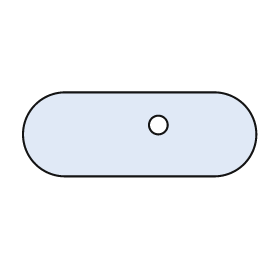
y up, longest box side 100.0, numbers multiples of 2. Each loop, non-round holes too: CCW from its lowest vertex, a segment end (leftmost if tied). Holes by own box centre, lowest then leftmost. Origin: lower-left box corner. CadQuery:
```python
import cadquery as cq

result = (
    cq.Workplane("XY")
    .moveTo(18.0, 0.0)
    .lineTo(82.0, 0.0)
    .threePointArc((100.0, 18.0), (82.0, 36.0))
    .lineTo(18.0, 36.0)
    .threePointArc((0.0, 18.0), (18.0, 0.0))
    .close()
    .moveTo(58.0, 22.0)
    .circle(4.0)
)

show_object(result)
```